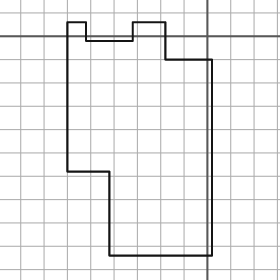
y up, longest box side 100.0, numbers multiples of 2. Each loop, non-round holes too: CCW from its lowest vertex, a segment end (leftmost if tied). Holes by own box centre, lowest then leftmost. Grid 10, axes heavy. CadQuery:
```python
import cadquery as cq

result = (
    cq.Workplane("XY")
    .moveTo(-42.0, -94.0)
    .lineTo(2.0, -94.0)
    .lineTo(2.0, -10.0)
    .lineTo(-18.0, -10.0)
    .lineTo(-18.0, 6.0)
    .lineTo(-32.0, 6.0)
    .lineTo(-32.0, -2.0)
    .lineTo(-52.0, -2.0)
    .lineTo(-52.0, 6.0)
    .lineTo(-60.0, 6.0)
    .lineTo(-60.0, -58.0)
    .lineTo(-42.0, -58.0)
    .close()
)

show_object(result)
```